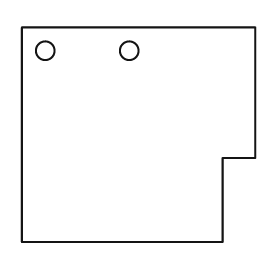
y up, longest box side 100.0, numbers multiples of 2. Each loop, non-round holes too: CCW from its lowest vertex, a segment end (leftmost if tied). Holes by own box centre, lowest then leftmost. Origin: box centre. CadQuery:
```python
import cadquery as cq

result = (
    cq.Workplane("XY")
    .moveTo(-50.0, -46.0)
    .lineTo(36.0, -46.0)
    .lineTo(36.0, -10.0)
    .lineTo(50.0, -10.0)
    .lineTo(50.0, 46.0)
    .lineTo(-50.0, 46.0)
    .close()
    .moveTo(-40.0, 36.0)
    .circle(4.0)
    .moveTo(-4.0, 36.0)
    .circle(4.0)
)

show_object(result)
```